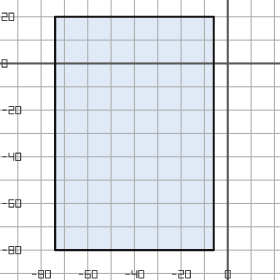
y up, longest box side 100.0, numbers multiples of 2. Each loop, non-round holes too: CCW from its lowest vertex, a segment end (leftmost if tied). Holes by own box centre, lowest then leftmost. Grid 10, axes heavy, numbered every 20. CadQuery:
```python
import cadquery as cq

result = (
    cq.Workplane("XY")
    .moveTo(-74.0, -80.0)
    .lineTo(-6.0, -80.0)
    .lineTo(-6.0, 20.0)
    .lineTo(-74.0, 20.0)
    .close()
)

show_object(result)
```